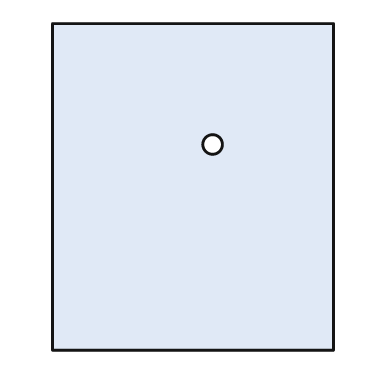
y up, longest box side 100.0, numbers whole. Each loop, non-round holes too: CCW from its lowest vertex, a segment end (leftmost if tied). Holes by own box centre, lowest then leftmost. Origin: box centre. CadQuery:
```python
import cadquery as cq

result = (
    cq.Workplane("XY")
    .moveTo(-43.0, -50.0)
    .lineTo(43.0, -50.0)
    .lineTo(43.0, 50.0)
    .lineTo(-43.0, 50.0)
    .close()
    .moveTo(6.0, 13.0)
    .circle(3.0)
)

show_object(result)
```